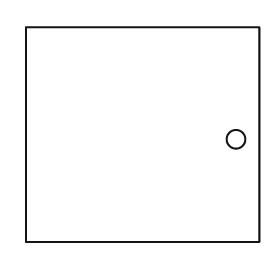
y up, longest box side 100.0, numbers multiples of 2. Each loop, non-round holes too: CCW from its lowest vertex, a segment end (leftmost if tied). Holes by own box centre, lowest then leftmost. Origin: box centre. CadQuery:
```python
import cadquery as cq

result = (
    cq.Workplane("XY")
    .moveTo(-50.0, -46.0)
    .lineTo(50.0, -46.0)
    .lineTo(50.0, 46.0)
    .lineTo(-50.0, 46.0)
    .close()
    .moveTo(40.0, -2.0)
    .circle(4.0)
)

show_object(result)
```